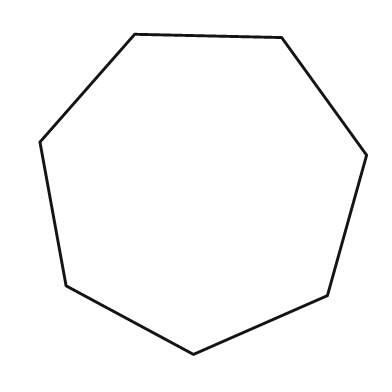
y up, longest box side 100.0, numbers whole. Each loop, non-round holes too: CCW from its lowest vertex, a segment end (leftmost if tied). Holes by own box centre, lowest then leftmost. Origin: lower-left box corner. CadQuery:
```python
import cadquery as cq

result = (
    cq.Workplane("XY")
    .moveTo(47.0, 0.0)
    .lineTo(88.0, 18.0)
    .lineTo(100.0, 61.0)
    .lineTo(74.0, 97.0)
    .lineTo(29.0, 98.0)
    .lineTo(0.0, 65.0)
    .lineTo(8.0, 21.0)
    .close()
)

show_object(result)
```